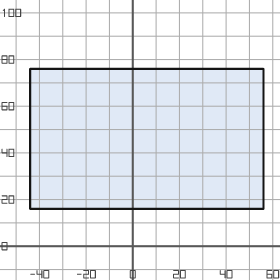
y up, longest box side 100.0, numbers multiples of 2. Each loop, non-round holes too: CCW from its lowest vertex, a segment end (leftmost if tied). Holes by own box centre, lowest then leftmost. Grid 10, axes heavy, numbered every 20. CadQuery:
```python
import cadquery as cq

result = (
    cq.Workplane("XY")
    .moveTo(-44.0, 16.0)
    .lineTo(56.0, 16.0)
    .lineTo(56.0, 76.0)
    .lineTo(-44.0, 76.0)
    .close()
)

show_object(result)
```